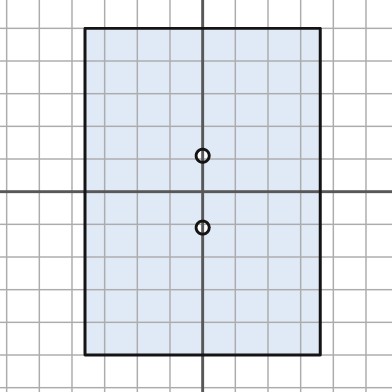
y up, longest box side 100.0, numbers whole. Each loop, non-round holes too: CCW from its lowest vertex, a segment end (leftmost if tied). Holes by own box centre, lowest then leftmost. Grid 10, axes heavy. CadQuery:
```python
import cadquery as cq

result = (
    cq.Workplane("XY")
    .moveTo(-36.0, -50.0)
    .lineTo(36.0, -50.0)
    .lineTo(36.0, 50.0)
    .lineTo(-36.0, 50.0)
    .close()
    .moveTo(0.0, -11.0)
    .circle(2.0)
    .moveTo(0.0, 11.0)
    .circle(2.0)
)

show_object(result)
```